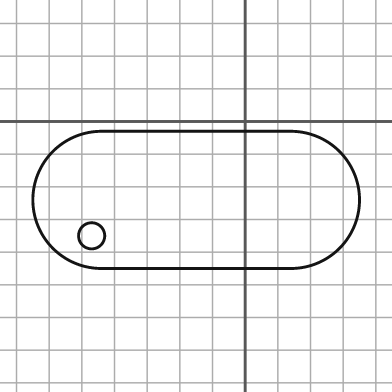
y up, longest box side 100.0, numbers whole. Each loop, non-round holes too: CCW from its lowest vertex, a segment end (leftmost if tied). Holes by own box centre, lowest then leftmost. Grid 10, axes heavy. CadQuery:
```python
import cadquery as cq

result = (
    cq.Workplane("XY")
    .moveTo(-44.0, -45.0)
    .lineTo(14.0, -45.0)
    .threePointArc((35.0, -24.0), (14.0, -3.0))
    .lineTo(-44.0, -3.0)
    .threePointArc((-65.0, -24.0), (-44.0, -45.0))
    .close()
    .moveTo(-47.0, -35.0)
    .circle(4.0)
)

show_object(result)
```